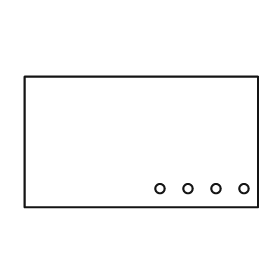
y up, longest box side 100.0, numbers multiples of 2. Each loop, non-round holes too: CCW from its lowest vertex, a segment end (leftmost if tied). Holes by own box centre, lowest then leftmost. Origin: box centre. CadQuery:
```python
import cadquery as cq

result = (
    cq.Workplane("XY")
    .moveTo(-50.0, -28.0)
    .lineTo(50.0, -28.0)
    .lineTo(50.0, 28.0)
    .lineTo(-50.0, 28.0)
    .close()
    .moveTo(8.0, -20.0)
    .circle(2.0)
    .moveTo(20.0, -20.0)
    .circle(2.0)
    .moveTo(32.0, -20.0)
    .circle(2.0)
    .moveTo(44.0, -20.0)
    .circle(2.0)
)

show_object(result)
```